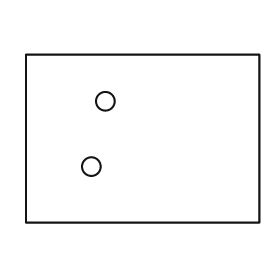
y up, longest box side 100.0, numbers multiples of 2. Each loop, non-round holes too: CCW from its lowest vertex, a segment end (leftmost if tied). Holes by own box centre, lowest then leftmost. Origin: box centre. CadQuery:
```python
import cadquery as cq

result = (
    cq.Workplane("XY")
    .moveTo(-50.0, -36.0)
    .lineTo(50.0, -36.0)
    .lineTo(50.0, 36.0)
    .lineTo(-50.0, 36.0)
    .close()
    .moveTo(-22.0, -12.0)
    .circle(4.0)
    .moveTo(-16.0, 16.0)
    .circle(4.0)
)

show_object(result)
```